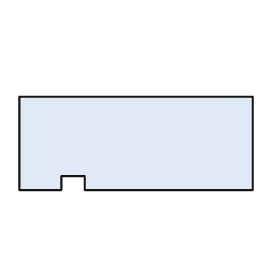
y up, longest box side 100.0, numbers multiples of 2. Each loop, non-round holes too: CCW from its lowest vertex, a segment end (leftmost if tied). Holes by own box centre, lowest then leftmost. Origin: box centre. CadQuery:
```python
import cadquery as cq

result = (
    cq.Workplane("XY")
    .moveTo(-50.0, -20.0)
    .lineTo(-32.0, -20.0)
    .lineTo(-32.0, -14.0)
    .lineTo(-22.0, -14.0)
    .lineTo(-22.0, -20.0)
    .lineTo(50.0, -20.0)
    .lineTo(50.0, 20.0)
    .lineTo(-50.0, 20.0)
    .close()
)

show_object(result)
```